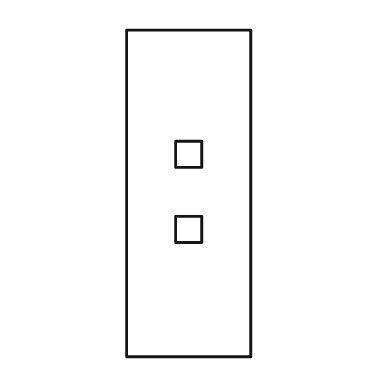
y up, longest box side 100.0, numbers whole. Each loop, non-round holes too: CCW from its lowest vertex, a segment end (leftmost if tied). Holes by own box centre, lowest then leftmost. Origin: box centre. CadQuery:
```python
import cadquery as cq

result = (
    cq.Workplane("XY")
    .moveTo(-19.0, -50.0)
    .lineTo(19.0, -50.0)
    .lineTo(19.0, 50.0)
    .lineTo(-19.0, 50.0)
    .close()
    .moveTo(-4.0, -15.0)
    .lineTo(4.0, -15.0)
    .lineTo(4.0, -7.0)
    .lineTo(-4.0, -7.0)
    .close()
    .moveTo(-4.0, 8.0)
    .lineTo(4.0, 8.0)
    .lineTo(4.0, 16.0)
    .lineTo(-4.0, 16.0)
    .close()
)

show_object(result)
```